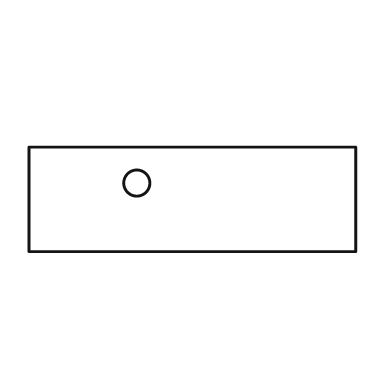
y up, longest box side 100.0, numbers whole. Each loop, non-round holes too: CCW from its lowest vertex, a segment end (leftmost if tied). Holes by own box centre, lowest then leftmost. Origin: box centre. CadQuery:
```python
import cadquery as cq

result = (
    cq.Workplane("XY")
    .moveTo(-50.0, -16.0)
    .lineTo(50.0, -16.0)
    .lineTo(50.0, 16.0)
    .lineTo(-50.0, 16.0)
    .close()
    .moveTo(-17.0, 5.0)
    .circle(4.0)
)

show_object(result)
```